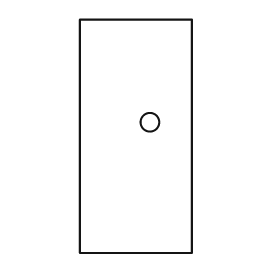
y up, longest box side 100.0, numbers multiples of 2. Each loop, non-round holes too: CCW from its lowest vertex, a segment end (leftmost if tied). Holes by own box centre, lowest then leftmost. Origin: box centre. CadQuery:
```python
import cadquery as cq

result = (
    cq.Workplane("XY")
    .moveTo(-24.0, -50.0)
    .lineTo(24.0, -50.0)
    .lineTo(24.0, 50.0)
    .lineTo(-24.0, 50.0)
    .close()
    .moveTo(6.0, 6.0)
    .circle(4.0)
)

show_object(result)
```